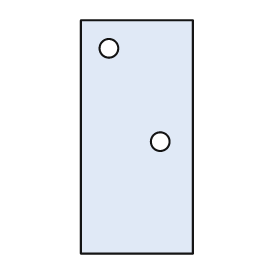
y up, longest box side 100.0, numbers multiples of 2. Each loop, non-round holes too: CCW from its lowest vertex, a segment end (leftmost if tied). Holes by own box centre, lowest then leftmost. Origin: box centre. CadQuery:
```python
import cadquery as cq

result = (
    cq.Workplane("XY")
    .moveTo(-24.0, -50.0)
    .lineTo(24.0, -50.0)
    .lineTo(24.0, 50.0)
    .lineTo(-24.0, 50.0)
    .close()
    .moveTo(10.0, -2.0)
    .circle(4.0)
    .moveTo(-12.0, 38.0)
    .circle(4.0)
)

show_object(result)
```